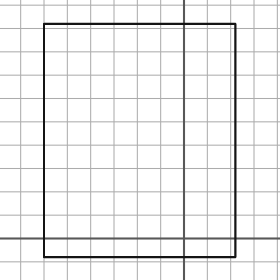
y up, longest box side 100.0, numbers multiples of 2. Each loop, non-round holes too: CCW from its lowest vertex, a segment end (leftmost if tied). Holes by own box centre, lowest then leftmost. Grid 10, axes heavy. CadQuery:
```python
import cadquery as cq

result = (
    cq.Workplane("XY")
    .moveTo(-60.0, -8.0)
    .lineTo(22.0, -8.0)
    .lineTo(22.0, 92.0)
    .lineTo(-60.0, 92.0)
    .close()
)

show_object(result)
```